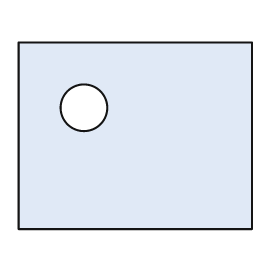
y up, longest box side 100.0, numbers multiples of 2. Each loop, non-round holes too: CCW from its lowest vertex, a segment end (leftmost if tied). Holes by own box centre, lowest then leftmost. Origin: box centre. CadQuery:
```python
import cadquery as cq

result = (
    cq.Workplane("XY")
    .moveTo(-50.0, -40.0)
    .lineTo(50.0, -40.0)
    .lineTo(50.0, 40.0)
    .lineTo(-50.0, 40.0)
    .close()
    .moveTo(-22.0, 12.0)
    .circle(10.0)
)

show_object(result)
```